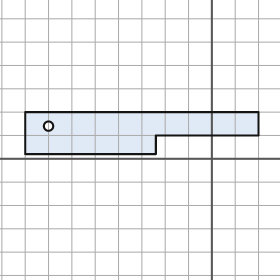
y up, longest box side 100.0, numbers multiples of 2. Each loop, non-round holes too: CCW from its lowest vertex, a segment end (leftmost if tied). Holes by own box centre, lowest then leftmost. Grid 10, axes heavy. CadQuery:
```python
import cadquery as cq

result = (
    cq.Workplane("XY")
    .moveTo(-80.0, 2.0)
    .lineTo(-24.0, 2.0)
    .lineTo(-24.0, 10.0)
    .lineTo(20.0, 10.0)
    .lineTo(20.0, 20.0)
    .lineTo(-80.0, 20.0)
    .close()
    .moveTo(-70.0, 14.0)
    .circle(2.0)
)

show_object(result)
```